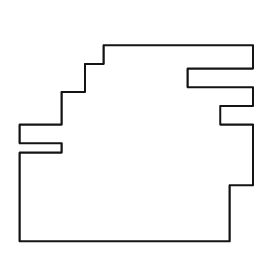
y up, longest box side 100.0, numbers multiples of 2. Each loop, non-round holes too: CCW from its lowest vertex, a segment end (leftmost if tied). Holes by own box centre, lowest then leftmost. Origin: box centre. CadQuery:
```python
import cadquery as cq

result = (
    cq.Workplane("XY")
    .moveTo(-50.0, -42.0)
    .lineTo(40.0, -42.0)
    .lineTo(40.0, -18.0)
    .lineTo(50.0, -18.0)
    .lineTo(50.0, 8.0)
    .lineTo(36.0, 8.0)
    .lineTo(36.0, 16.0)
    .lineTo(50.0, 16.0)
    .lineTo(50.0, 24.0)
    .lineTo(22.0, 24.0)
    .lineTo(22.0, 32.0)
    .lineTo(50.0, 32.0)
    .lineTo(50.0, 42.0)
    .lineTo(-14.0, 42.0)
    .lineTo(-14.0, 34.0)
    .lineTo(-22.0, 34.0)
    .lineTo(-22.0, 22.0)
    .lineTo(-32.0, 22.0)
    .lineTo(-32.0, 8.0)
    .lineTo(-50.0, 8.0)
    .lineTo(-50.0, 0.0)
    .lineTo(-32.0, 0.0)
    .lineTo(-32.0, -4.0)
    .lineTo(-50.0, -4.0)
    .close()
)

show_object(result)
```